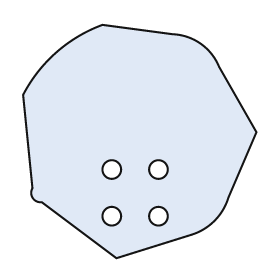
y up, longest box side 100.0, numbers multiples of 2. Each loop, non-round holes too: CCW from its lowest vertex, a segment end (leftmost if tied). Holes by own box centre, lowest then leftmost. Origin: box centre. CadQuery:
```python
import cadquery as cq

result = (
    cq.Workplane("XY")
    .moveTo(-10.0, -50.0)
    .lineTo(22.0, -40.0)
    .threePointArc((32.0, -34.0), (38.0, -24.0))
    .lineTo(50.0, 4.0)
    .lineTo(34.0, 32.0)
    .threePointArc((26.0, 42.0), (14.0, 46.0))
    .lineTo(-16.0, 50.0)
    .threePointArc((-36.0, 38.0), (-50.0, 20.0))
    .lineTo(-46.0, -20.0)
    .threePointArc((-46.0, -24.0), (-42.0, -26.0))
    .close()
    .moveTo(-12.0, -32.0)
    .circle(4.0)
    .moveTo(8.0, -32.0)
    .circle(4.0)
    .moveTo(-12.0, -12.0)
    .circle(4.0)
    .moveTo(8.0, -12.0)
    .circle(4.0)
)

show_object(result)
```